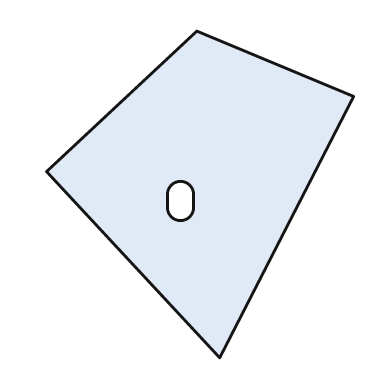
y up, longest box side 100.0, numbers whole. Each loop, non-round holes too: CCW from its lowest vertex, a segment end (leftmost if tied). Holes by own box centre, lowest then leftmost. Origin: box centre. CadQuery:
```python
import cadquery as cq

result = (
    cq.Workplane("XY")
    .moveTo(6.0, -50.0)
    .lineTo(47.0, 30.0)
    .lineTo(-1.0, 50.0)
    .lineTo(-47.0, 7.0)
    .close()
    .moveTo(-10.0, -4.0)
    .threePointArc((-6.0, -8.0), (-2.0, -4.0))
    .lineTo(-2.0, 0.0)
    .threePointArc((-6.0, 4.0), (-10.0, 0.0))
    .close()
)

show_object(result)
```